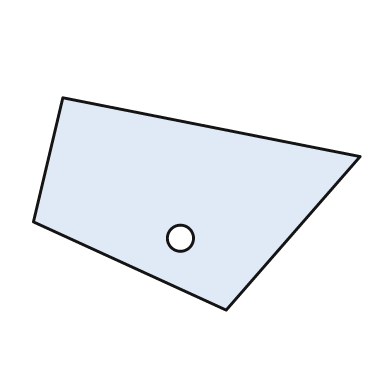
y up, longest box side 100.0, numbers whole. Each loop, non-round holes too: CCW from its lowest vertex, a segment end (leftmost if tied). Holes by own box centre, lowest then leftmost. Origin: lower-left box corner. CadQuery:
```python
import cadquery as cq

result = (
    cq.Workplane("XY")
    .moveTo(59.0, 0.0)
    .lineTo(100.0, 47.0)
    .lineTo(9.0, 65.0)
    .lineTo(0.0, 27.0)
    .close()
    .moveTo(45.0, 22.0)
    .circle(4.0)
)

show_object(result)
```